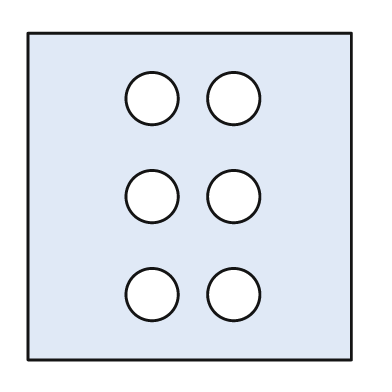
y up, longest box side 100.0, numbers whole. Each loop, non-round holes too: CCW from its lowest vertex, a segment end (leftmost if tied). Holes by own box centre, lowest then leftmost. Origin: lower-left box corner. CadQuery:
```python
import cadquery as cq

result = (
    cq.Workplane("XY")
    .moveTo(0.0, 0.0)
    .lineTo(99.0, 0.0)
    .lineTo(99.0, 100.0)
    .lineTo(0.0, 100.0)
    .close()
    .moveTo(38.0, 20.0)
    .circle(8.0)
    .moveTo(63.0, 20.0)
    .circle(8.0)
    .moveTo(38.0, 50.0)
    .circle(8.0)
    .moveTo(63.0, 50.0)
    .circle(8.0)
    .moveTo(38.0, 80.0)
    .circle(8.0)
    .moveTo(63.0, 80.0)
    .circle(8.0)
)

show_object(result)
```